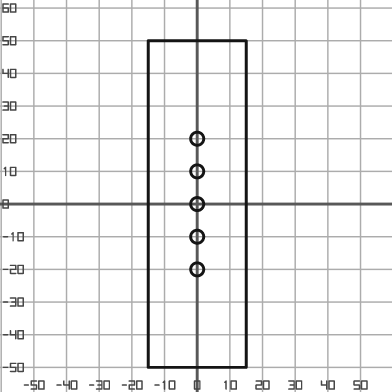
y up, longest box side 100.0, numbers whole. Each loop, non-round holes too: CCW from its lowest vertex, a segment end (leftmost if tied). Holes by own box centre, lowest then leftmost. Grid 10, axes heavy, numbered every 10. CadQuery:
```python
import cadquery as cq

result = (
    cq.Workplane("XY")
    .moveTo(-15.0, -50.0)
    .lineTo(15.0, -50.0)
    .lineTo(15.0, 50.0)
    .lineTo(-15.0, 50.0)
    .close()
    .moveTo(0.0, -20.0)
    .circle(2.0)
    .moveTo(0.0, -10.0)
    .circle(2.0)
    .moveTo(0.0, 0.0)
    .circle(2.0)
    .moveTo(0.0, 10.0)
    .circle(2.0)
    .moveTo(0.0, 20.0)
    .circle(2.0)
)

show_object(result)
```